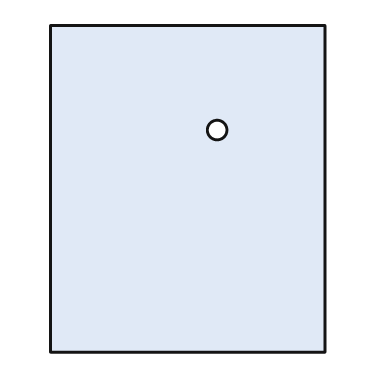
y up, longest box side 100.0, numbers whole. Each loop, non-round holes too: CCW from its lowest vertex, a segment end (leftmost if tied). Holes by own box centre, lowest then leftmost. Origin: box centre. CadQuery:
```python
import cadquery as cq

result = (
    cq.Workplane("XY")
    .moveTo(-42.0, -50.0)
    .lineTo(42.0, -50.0)
    .lineTo(42.0, 50.0)
    .lineTo(-42.0, 50.0)
    .close()
    .moveTo(9.0, 18.0)
    .circle(3.0)
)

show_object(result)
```